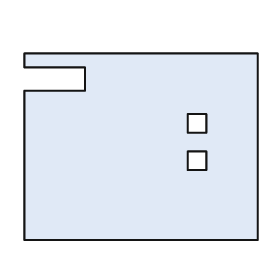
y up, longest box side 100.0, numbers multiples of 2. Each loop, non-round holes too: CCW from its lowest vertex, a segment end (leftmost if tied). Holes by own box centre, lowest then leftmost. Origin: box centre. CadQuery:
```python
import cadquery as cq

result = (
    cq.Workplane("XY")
    .moveTo(-50.0, -40.0)
    .lineTo(50.0, -40.0)
    .lineTo(50.0, 40.0)
    .lineTo(-50.0, 40.0)
    .lineTo(-50.0, 34.0)
    .lineTo(-24.0, 34.0)
    .lineTo(-24.0, 24.0)
    .lineTo(-50.0, 24.0)
    .close()
    .moveTo(20.0, -10.0)
    .lineTo(28.0, -10.0)
    .lineTo(28.0, -2.0)
    .lineTo(20.0, -2.0)
    .close()
    .moveTo(20.0, 6.0)
    .lineTo(28.0, 6.0)
    .lineTo(28.0, 14.0)
    .lineTo(20.0, 14.0)
    .close()
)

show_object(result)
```